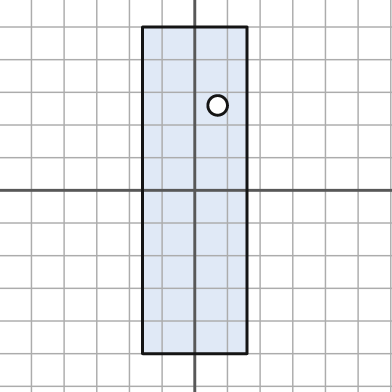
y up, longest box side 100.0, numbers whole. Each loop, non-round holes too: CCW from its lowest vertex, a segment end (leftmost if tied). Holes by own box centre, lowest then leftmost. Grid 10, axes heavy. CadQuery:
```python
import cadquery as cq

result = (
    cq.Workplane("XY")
    .moveTo(-16.0, -50.0)
    .lineTo(16.0, -50.0)
    .lineTo(16.0, 50.0)
    .lineTo(-16.0, 50.0)
    .close()
    .moveTo(7.0, 26.0)
    .circle(3.0)
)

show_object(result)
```